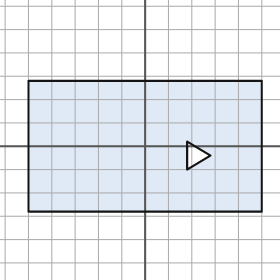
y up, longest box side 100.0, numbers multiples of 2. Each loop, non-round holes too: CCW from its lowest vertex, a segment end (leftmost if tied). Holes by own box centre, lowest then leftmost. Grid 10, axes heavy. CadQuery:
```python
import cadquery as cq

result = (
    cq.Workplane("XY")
    .moveTo(-50.0, -28.0)
    .lineTo(50.0, -28.0)
    .lineTo(50.0, 28.0)
    .lineTo(-50.0, 28.0)
    .close()
    .moveTo(18.0, -10.0)
    .lineTo(28.0, -4.0)
    .lineTo(18.0, 2.0)
    .close()
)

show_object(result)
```